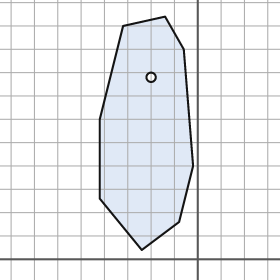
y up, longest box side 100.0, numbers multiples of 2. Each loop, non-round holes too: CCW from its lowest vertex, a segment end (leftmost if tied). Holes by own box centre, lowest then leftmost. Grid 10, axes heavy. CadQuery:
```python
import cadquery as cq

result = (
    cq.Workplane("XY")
    .moveTo(-24.0, 4.0)
    .lineTo(-8.0, 16.0)
    .lineTo(-2.0, 40.0)
    .lineTo(-6.0, 90.0)
    .lineTo(-14.0, 104.0)
    .lineTo(-32.0, 100.0)
    .lineTo(-42.0, 60.0)
    .lineTo(-42.0, 26.0)
    .close()
    .moveTo(-20.0, 78.0)
    .circle(2.0)
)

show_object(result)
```